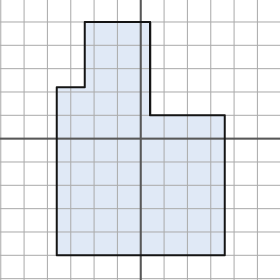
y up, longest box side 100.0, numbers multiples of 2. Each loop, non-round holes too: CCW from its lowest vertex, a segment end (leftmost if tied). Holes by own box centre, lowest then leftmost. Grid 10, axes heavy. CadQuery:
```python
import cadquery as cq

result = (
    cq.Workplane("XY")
    .moveTo(-36.0, -50.0)
    .lineTo(36.0, -50.0)
    .lineTo(36.0, 10.0)
    .lineTo(4.0, 10.0)
    .lineTo(4.0, 50.0)
    .lineTo(-24.0, 50.0)
    .lineTo(-24.0, 22.0)
    .lineTo(-36.0, 22.0)
    .close()
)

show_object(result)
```